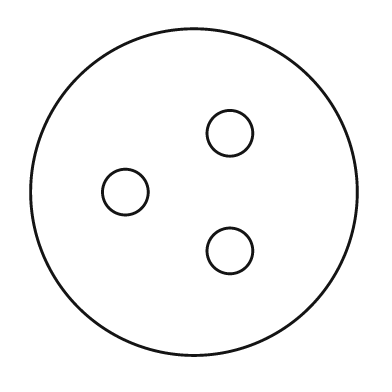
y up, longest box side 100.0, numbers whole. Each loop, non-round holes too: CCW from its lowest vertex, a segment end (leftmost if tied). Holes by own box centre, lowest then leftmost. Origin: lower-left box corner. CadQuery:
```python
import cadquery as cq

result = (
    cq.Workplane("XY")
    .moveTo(50.0, 50.0)
    .circle(50.0)
    .moveTo(61.0, 32.0)
    .circle(7.0)
    .moveTo(29.0, 50.0)
    .circle(7.0)
    .moveTo(61.0, 68.0)
    .circle(7.0)
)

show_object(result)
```